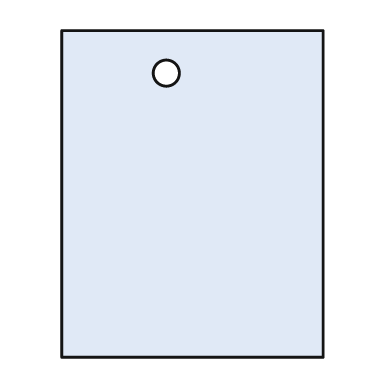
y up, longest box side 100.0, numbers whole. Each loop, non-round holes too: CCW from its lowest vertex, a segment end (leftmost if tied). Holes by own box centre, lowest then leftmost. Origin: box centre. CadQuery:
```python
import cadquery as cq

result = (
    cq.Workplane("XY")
    .moveTo(-40.0, -50.0)
    .lineTo(40.0, -50.0)
    .lineTo(40.0, 50.0)
    .lineTo(-40.0, 50.0)
    .close()
    .moveTo(-8.0, 37.0)
    .circle(4.0)
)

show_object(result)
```